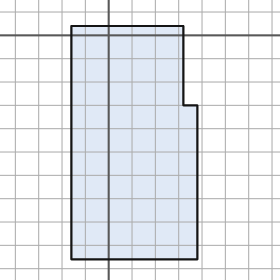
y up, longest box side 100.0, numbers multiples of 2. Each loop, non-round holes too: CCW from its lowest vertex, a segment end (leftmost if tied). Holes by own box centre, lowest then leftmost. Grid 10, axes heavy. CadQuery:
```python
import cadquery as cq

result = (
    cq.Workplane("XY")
    .moveTo(-16.0, -96.0)
    .lineTo(38.0, -96.0)
    .lineTo(38.0, -30.0)
    .lineTo(32.0, -30.0)
    .lineTo(32.0, 4.0)
    .lineTo(-16.0, 4.0)
    .close()
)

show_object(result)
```